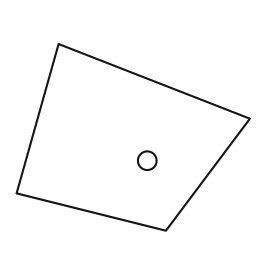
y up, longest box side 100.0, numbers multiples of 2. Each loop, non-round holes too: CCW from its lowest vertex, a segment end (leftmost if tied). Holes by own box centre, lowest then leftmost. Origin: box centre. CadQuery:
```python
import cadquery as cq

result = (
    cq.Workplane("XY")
    .moveTo(14.0, -40.0)
    .lineTo(50.0, 8.0)
    .lineTo(-32.0, 40.0)
    .lineTo(-50.0, -24.0)
    .close()
    .moveTo(6.0, -10.0)
    .circle(4.0)
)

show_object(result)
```